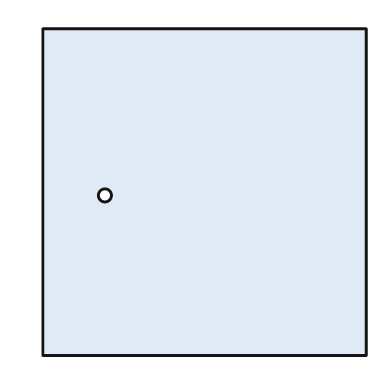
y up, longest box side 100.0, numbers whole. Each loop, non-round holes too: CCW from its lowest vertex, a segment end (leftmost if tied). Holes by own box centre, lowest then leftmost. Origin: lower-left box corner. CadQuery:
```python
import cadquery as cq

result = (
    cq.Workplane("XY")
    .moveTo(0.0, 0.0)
    .lineTo(99.0, 0.0)
    .lineTo(99.0, 100.0)
    .lineTo(0.0, 100.0)
    .close()
    .moveTo(19.0, 49.0)
    .circle(2.0)
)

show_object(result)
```